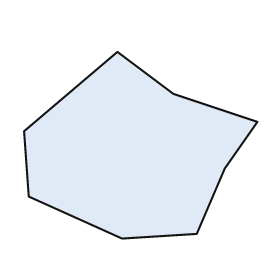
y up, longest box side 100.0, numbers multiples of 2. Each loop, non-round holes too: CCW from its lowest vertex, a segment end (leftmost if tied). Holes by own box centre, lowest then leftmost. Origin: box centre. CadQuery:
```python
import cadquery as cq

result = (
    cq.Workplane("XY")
    .moveTo(-8.0, -40.0)
    .lineTo(24.0, -38.0)
    .lineTo(36.0, -10.0)
    .lineTo(50.0, 10.0)
    .lineTo(14.0, 22.0)
    .lineTo(-10.0, 40.0)
    .lineTo(-50.0, 6.0)
    .lineTo(-48.0, -22.0)
    .close()
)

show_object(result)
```